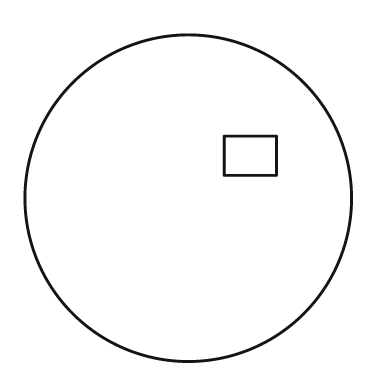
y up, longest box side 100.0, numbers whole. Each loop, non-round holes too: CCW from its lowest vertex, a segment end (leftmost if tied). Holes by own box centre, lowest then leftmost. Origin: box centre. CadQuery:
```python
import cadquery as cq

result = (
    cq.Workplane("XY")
    .moveTo(0.0, 0.0)
    .circle(50.0)
    .moveTo(11.0, 7.0)
    .lineTo(27.0, 7.0)
    .lineTo(27.0, 19.0)
    .lineTo(11.0, 19.0)
    .close()
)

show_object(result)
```